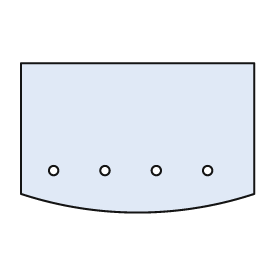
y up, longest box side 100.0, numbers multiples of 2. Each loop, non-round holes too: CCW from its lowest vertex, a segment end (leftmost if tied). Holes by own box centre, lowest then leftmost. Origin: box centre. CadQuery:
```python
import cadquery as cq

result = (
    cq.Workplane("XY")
    .moveTo(-50.0, -24.0)
    .threePointArc((0.0, -32.0), (50.0, -24.0))
    .lineTo(50.0, 32.0)
    .lineTo(-50.0, 32.0)
    .close()
    .moveTo(-36.0, -14.0)
    .circle(2.0)
    .moveTo(-14.0, -14.0)
    .circle(2.0)
    .moveTo(8.0, -14.0)
    .circle(2.0)
    .moveTo(30.0, -14.0)
    .circle(2.0)
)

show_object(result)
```